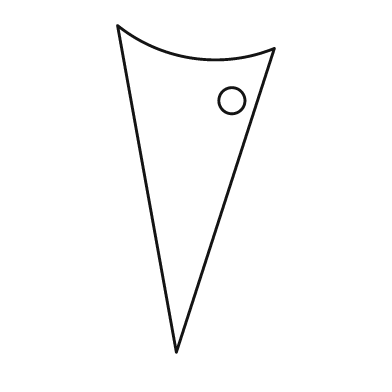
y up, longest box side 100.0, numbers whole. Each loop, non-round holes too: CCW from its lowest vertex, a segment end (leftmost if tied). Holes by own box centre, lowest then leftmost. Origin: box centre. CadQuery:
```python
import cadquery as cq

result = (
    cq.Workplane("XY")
    .moveTo(-6.0, -50.0)
    .lineTo(24.0, 43.0)
    .threePointArc((-1.0, 40.0), (-24.0, 50.0))
    .close()
    .moveTo(11.0, 27.0)
    .circle(4.0)
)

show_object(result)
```